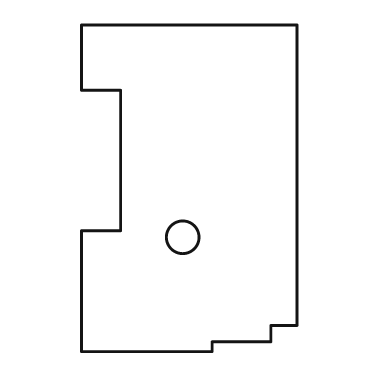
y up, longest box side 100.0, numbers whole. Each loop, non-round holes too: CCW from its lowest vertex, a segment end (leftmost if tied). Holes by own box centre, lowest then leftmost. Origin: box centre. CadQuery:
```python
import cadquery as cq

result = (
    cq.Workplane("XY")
    .moveTo(-33.0, -50.0)
    .lineTo(7.0, -50.0)
    .lineTo(7.0, -47.0)
    .lineTo(25.0, -47.0)
    .lineTo(25.0, -42.0)
    .lineTo(33.0, -42.0)
    .lineTo(33.0, 50.0)
    .lineTo(-33.0, 50.0)
    .lineTo(-33.0, 30.0)
    .lineTo(-21.0, 30.0)
    .lineTo(-21.0, -13.0)
    .lineTo(-33.0, -13.0)
    .close()
    .moveTo(-2.0, -15.0)
    .circle(5.0)
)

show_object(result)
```